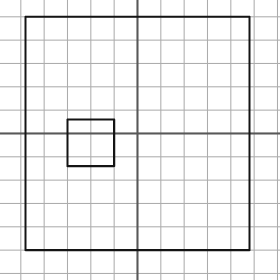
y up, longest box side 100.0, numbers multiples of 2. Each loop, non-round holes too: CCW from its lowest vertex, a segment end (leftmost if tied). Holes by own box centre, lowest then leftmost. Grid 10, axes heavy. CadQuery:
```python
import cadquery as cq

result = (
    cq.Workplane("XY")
    .moveTo(-48.0, -50.0)
    .lineTo(48.0, -50.0)
    .lineTo(48.0, 50.0)
    .lineTo(-48.0, 50.0)
    .close()
    .moveTo(-30.0, -14.0)
    .lineTo(-10.0, -14.0)
    .lineTo(-10.0, 6.0)
    .lineTo(-30.0, 6.0)
    .close()
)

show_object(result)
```